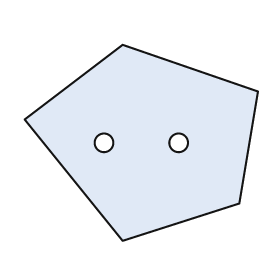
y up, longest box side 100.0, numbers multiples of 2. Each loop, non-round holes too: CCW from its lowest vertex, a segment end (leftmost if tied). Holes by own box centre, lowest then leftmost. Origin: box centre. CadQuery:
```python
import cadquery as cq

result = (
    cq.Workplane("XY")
    .moveTo(-8.0, -42.0)
    .lineTo(42.0, -26.0)
    .lineTo(50.0, 22.0)
    .lineTo(-8.0, 42.0)
    .lineTo(-50.0, 10.0)
    .close()
    .moveTo(-16.0, 0.0)
    .circle(4.0)
    .moveTo(16.0, 0.0)
    .circle(4.0)
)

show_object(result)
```